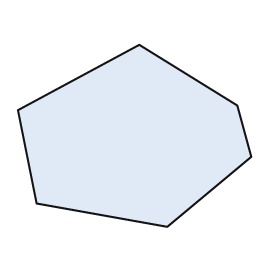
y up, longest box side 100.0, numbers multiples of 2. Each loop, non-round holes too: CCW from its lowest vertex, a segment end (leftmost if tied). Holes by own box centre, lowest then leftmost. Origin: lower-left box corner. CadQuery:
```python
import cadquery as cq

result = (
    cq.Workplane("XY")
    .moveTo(64.0, 0.0)
    .lineTo(100.0, 30.0)
    .lineTo(94.0, 52.0)
    .lineTo(52.0, 78.0)
    .lineTo(0.0, 50.0)
    .lineTo(8.0, 10.0)
    .close()
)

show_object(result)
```